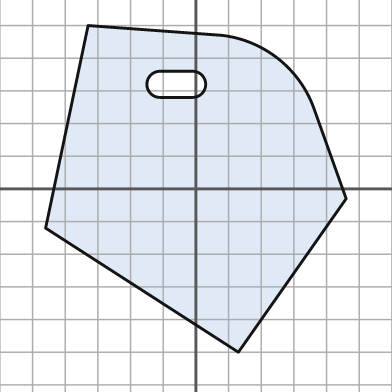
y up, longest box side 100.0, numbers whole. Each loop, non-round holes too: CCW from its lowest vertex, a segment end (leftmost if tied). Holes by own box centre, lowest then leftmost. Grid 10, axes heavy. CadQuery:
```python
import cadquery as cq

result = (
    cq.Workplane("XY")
    .moveTo(13.0, -50.0)
    .lineTo(46.0, -3.0)
    .lineTo(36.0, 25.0)
    .threePointArc((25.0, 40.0), (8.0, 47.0))
    .lineTo(-33.0, 50.0)
    .lineTo(-46.0, -12.0)
    .close()
    .moveTo(-11.0, 28.0)
    .lineTo(-1.0, 28.0)
    .threePointArc((3.0, 32.0), (-1.0, 36.0))
    .lineTo(-11.0, 36.0)
    .threePointArc((-15.0, 32.0), (-11.0, 28.0))
    .close()
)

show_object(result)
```